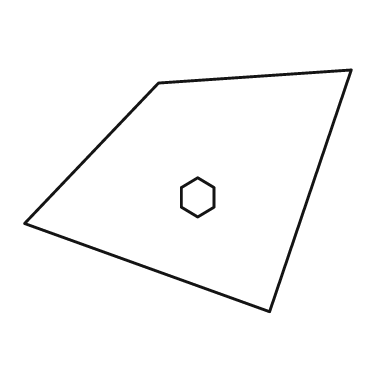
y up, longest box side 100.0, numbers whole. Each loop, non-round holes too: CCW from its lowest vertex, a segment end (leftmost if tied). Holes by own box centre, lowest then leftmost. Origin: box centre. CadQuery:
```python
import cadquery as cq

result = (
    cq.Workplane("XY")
    .moveTo(25.0, -37.0)
    .lineTo(50.0, 37.0)
    .lineTo(-9.0, 33.0)
    .lineTo(-50.0, -10.0)
    .close()
    .moveTo(3.0, -8.0)
    .lineTo(8.0, -5.0)
    .lineTo(8.0, 1.0)
    .lineTo(3.0, 4.0)
    .lineTo(-2.0, 1.0)
    .lineTo(-2.0, -5.0)
    .close()
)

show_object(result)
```